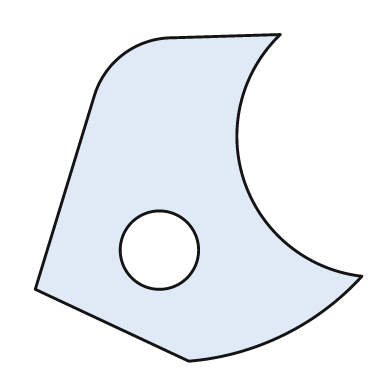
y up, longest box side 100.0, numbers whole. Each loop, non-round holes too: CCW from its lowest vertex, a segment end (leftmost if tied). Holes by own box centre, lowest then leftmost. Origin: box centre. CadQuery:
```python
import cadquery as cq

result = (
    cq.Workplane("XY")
    .moveTo(-3.0, -50.0)
    .threePointArc((26.0, -42.0), (50.0, -24.0))
    .threePointArc((14.0, 5.0), (25.0, 50.0))
    .lineTo(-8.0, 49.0)
    .threePointArc((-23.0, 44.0), (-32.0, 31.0))
    .lineTo(-50.0, -28.0)
    .close()
    .moveTo(-12.0, -16.0)
    .circle(12.0)
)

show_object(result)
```